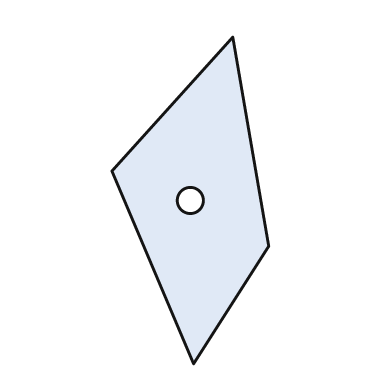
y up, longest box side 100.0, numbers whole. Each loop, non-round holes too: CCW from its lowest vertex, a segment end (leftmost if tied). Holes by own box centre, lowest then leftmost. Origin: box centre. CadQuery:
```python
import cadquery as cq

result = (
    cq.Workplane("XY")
    .moveTo(1.0, -50.0)
    .lineTo(24.0, -14.0)
    .lineTo(13.0, 50.0)
    .lineTo(-24.0, 9.0)
    .close()
    .moveTo(0.0, 0.0)
    .circle(4.0)
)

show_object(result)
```